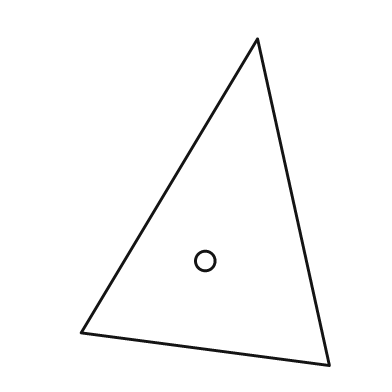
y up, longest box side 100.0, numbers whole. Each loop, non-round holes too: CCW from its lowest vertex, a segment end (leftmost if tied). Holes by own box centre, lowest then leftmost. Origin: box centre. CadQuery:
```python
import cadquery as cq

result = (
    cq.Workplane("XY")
    .moveTo(38.0, -50.0)
    .lineTo(16.0, 50.0)
    .lineTo(-38.0, -40.0)
    .close()
    .moveTo(0.0, -18.0)
    .circle(3.0)
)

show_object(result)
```